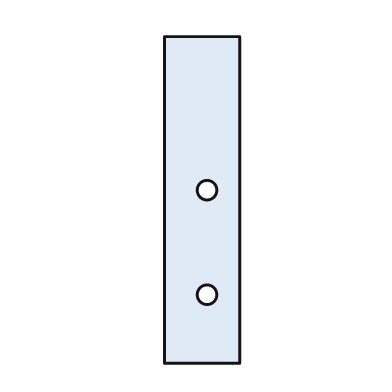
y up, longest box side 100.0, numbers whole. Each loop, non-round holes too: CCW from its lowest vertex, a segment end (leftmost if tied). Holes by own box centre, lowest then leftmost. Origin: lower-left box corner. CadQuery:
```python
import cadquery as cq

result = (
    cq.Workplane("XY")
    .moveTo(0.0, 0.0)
    .lineTo(23.0, 0.0)
    .lineTo(23.0, 100.0)
    .lineTo(0.0, 100.0)
    .close()
    .moveTo(13.0, 21.0)
    .circle(3.0)
    .moveTo(13.0, 53.0)
    .circle(3.0)
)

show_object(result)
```